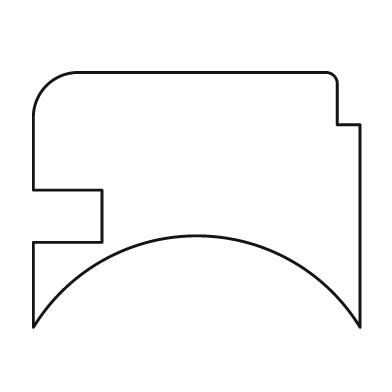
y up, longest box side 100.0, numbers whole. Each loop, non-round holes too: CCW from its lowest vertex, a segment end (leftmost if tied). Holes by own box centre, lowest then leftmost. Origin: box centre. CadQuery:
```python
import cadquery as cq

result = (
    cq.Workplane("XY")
    .moveTo(-50.0, -39.0)
    .threePointArc((0.0, -11.0), (50.0, -39.0))
    .lineTo(50.0, 23.0)
    .lineTo(43.0, 23.0)
    .lineTo(43.0, 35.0)
    .threePointArc((42.0, 38.0), (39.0, 39.0))
    .lineTo(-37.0, 39.0)
    .threePointArc((-46.0, 35.0), (-50.0, 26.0))
    .lineTo(-50.0, 3.0)
    .lineTo(-29.0, 3.0)
    .lineTo(-29.0, -13.0)
    .lineTo(-50.0, -13.0)
    .close()
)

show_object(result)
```